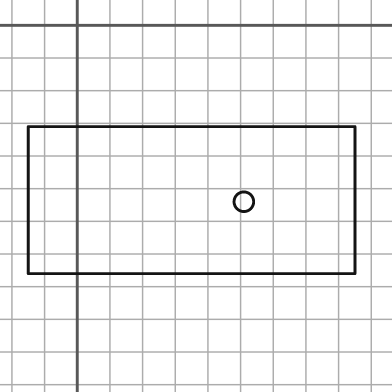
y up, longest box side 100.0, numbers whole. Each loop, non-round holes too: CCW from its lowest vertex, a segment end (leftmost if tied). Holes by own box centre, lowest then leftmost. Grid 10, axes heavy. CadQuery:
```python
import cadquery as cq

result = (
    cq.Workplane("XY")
    .moveTo(-15.0, -76.0)
    .lineTo(85.0, -76.0)
    .lineTo(85.0, -31.0)
    .lineTo(-15.0, -31.0)
    .close()
    .moveTo(51.0, -54.0)
    .circle(3.0)
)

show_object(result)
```